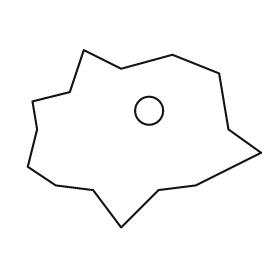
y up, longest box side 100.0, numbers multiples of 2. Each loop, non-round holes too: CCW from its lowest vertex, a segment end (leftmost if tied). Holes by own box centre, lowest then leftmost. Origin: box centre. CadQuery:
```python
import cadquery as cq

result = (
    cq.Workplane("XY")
    .moveTo(-10.0, -38.0)
    .lineTo(6.0, -22.0)
    .lineTo(22.0, -20.0)
    .lineTo(50.0, -6.0)
    .lineTo(36.0, 4.0)
    .lineTo(32.0, 28.0)
    .lineTo(12.0, 36.0)
    .lineTo(-10.0, 30.0)
    .lineTo(-26.0, 38.0)
    .lineTo(-32.0, 20.0)
    .lineTo(-48.0, 16.0)
    .lineTo(-46.0, 4.0)
    .lineTo(-50.0, -12.0)
    .lineTo(-38.0, -20.0)
    .lineTo(-22.0, -22.0)
    .close()
    .moveTo(2.0, 12.0)
    .circle(6.0)
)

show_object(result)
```